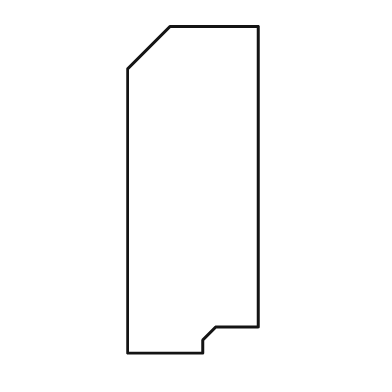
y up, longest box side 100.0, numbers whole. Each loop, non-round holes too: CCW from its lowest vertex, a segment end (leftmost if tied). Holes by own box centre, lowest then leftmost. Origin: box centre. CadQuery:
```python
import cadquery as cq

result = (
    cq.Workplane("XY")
    .moveTo(-20.0, -50.0)
    .lineTo(3.0, -50.0)
    .lineTo(3.0, -46.0)
    .lineTo(7.0, -42.0)
    .lineTo(20.0, -42.0)
    .lineTo(20.0, 50.0)
    .lineTo(-7.0, 50.0)
    .lineTo(-20.0, 37.0)
    .close()
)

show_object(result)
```